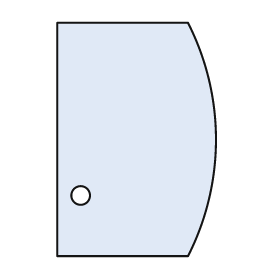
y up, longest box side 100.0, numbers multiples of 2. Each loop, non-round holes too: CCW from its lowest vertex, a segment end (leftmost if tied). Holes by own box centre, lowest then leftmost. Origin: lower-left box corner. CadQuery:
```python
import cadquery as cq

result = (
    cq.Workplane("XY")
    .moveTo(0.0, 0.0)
    .lineTo(56.0, 0.0)
    .threePointArc((68.0, 50.0), (56.0, 100.0))
    .lineTo(0.0, 100.0)
    .close()
    .moveTo(10.0, 26.0)
    .circle(4.0)
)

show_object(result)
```